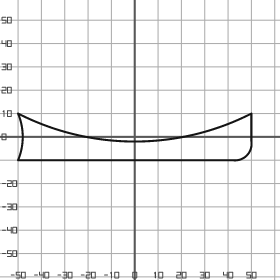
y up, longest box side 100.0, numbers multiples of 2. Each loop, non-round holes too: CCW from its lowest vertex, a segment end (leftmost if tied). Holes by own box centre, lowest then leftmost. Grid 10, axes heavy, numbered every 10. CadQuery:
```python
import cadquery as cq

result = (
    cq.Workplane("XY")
    .moveTo(-50.0, -10.0)
    .lineTo(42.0, -10.0)
    .threePointArc((48.0, -8.0), (50.0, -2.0))
    .lineTo(50.0, 10.0)
    .threePointArc((0.0, -2.0), (-50.0, 10.0))
    .threePointArc((-48.0, 0.0), (-50.0, -10.0))
    .close()
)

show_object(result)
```